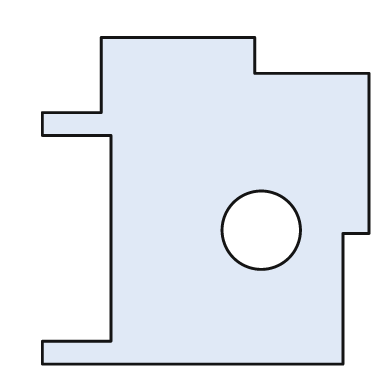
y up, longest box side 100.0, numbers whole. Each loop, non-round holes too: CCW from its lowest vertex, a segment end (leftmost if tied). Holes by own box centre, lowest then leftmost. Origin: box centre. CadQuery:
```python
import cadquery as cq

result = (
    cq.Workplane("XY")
    .moveTo(-50.0, -50.0)
    .lineTo(42.0, -50.0)
    .lineTo(42.0, -10.0)
    .lineTo(50.0, -10.0)
    .lineTo(50.0, 39.0)
    .lineTo(15.0, 39.0)
    .lineTo(15.0, 50.0)
    .lineTo(-32.0, 50.0)
    .lineTo(-32.0, 27.0)
    .lineTo(-50.0, 27.0)
    .lineTo(-50.0, 20.0)
    .lineTo(-29.0, 20.0)
    .lineTo(-29.0, -43.0)
    .lineTo(-50.0, -43.0)
    .close()
    .moveTo(17.0, -9.0)
    .circle(12.0)
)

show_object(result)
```